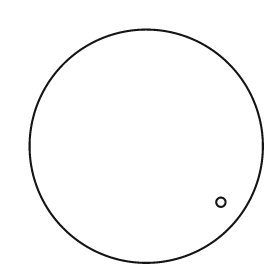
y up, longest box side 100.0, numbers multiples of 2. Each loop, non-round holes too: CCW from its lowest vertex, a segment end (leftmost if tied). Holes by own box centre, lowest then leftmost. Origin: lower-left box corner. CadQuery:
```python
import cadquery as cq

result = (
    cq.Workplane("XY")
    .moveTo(50.0, 50.0)
    .circle(50.0)
    .moveTo(82.0, 26.0)
    .circle(2.0)
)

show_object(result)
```